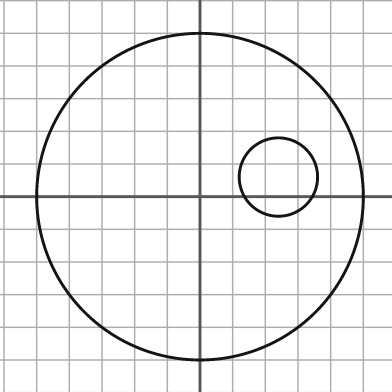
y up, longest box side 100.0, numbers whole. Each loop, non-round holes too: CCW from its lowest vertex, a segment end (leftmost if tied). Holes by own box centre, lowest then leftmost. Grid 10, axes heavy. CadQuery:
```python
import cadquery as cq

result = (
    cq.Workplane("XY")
    .moveTo(0.0, 0.0)
    .circle(50.0)
    .moveTo(24.0, 6.0)
    .circle(12.0)
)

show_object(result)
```